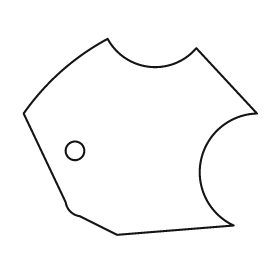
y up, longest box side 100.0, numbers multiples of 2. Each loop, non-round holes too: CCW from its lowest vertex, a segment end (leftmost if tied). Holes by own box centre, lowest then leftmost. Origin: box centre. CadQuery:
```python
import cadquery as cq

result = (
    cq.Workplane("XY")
    .moveTo(-10.0, -42.0)
    .lineTo(40.0, -38.0)
    .threePointArc((26.0, -10.0), (50.0, 10.0))
    .lineTo(24.0, 38.0)
    .threePointArc((4.0, 30.0), (-14.0, 42.0))
    .threePointArc((-34.0, 28.0), (-50.0, 10.0))
    .lineTo(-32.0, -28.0)
    .threePointArc((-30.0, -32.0), (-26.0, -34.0))
    .close()
    .moveTo(-28.0, -6.0)
    .circle(4.0)
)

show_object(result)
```